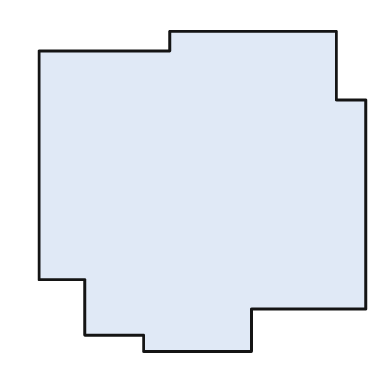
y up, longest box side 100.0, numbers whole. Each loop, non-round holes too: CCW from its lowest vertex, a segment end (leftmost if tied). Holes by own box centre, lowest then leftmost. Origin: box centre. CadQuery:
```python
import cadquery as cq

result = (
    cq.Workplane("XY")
    .moveTo(-18.0, -49.0)
    .lineTo(15.0, -49.0)
    .lineTo(15.0, -36.0)
    .lineTo(50.0, -36.0)
    .lineTo(50.0, 28.0)
    .lineTo(41.0, 28.0)
    .lineTo(41.0, 49.0)
    .lineTo(-10.0, 49.0)
    .lineTo(-10.0, 43.0)
    .lineTo(-50.0, 43.0)
    .lineTo(-50.0, -27.0)
    .lineTo(-36.0, -27.0)
    .lineTo(-36.0, -44.0)
    .lineTo(-18.0, -44.0)
    .close()
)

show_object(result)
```